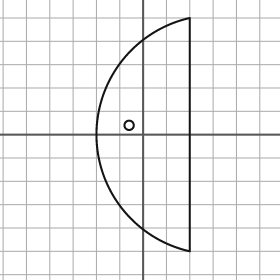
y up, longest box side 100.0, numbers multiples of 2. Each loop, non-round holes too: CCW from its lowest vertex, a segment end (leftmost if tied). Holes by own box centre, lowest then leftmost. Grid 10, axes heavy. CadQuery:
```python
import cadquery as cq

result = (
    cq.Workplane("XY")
    .moveTo(20.0, -50.0)
    .lineTo(20.0, 50.0)
    .threePointArc((-20.0, 0.0), (20.0, -50.0))
    .close()
    .moveTo(-6.0, 4.0)
    .circle(2.0)
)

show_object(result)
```